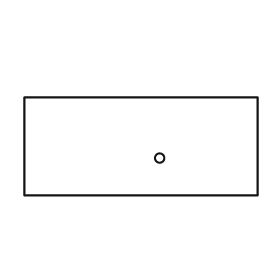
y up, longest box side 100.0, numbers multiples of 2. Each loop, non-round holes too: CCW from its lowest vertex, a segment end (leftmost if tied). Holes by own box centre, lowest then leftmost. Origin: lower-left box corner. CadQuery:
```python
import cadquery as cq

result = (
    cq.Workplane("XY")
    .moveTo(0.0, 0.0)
    .lineTo(100.0, 0.0)
    .lineTo(100.0, 42.0)
    .lineTo(0.0, 42.0)
    .close()
    .moveTo(58.0, 16.0)
    .circle(2.0)
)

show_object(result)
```